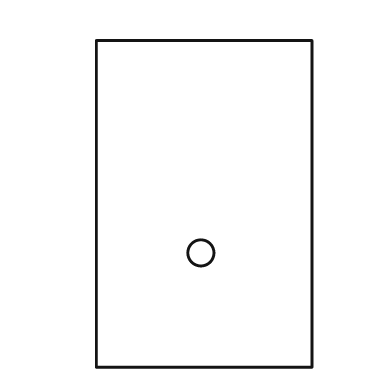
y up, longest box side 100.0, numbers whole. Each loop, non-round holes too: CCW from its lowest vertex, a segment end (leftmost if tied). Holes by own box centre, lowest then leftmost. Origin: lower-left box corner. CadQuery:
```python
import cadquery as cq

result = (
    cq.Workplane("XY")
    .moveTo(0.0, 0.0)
    .lineTo(66.0, 0.0)
    .lineTo(66.0, 100.0)
    .lineTo(0.0, 100.0)
    .close()
    .moveTo(32.0, 35.0)
    .circle(4.0)
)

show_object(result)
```